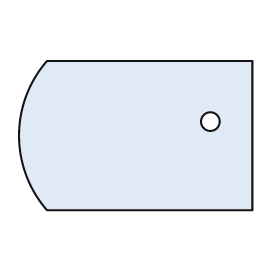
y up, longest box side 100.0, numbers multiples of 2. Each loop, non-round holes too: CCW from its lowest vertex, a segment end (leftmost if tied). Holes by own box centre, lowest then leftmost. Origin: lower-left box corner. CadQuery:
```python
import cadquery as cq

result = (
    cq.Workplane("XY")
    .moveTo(12.0, 0.0)
    .lineTo(100.0, 0.0)
    .lineTo(100.0, 64.0)
    .lineTo(12.0, 64.0)
    .threePointArc((0.0, 32.0), (12.0, 0.0))
    .close()
    .moveTo(82.0, 38.0)
    .circle(4.0)
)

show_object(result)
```